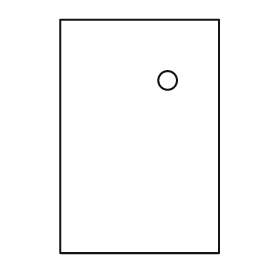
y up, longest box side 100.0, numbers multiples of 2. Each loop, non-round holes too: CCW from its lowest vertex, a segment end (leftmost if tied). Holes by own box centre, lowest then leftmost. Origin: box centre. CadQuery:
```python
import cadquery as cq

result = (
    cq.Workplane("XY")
    .moveTo(-34.0, -50.0)
    .lineTo(34.0, -50.0)
    .lineTo(34.0, 50.0)
    .lineTo(-34.0, 50.0)
    .close()
    .moveTo(12.0, 24.0)
    .circle(4.0)
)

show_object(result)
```